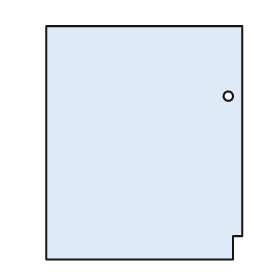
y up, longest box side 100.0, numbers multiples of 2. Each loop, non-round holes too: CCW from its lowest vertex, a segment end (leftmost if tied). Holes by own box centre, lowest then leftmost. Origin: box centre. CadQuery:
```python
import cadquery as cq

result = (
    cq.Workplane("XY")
    .moveTo(-42.0, -50.0)
    .lineTo(38.0, -50.0)
    .lineTo(38.0, -40.0)
    .lineTo(42.0, -40.0)
    .lineTo(42.0, 50.0)
    .lineTo(-42.0, 50.0)
    .close()
    .moveTo(36.0, 20.0)
    .circle(2.0)
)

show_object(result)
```